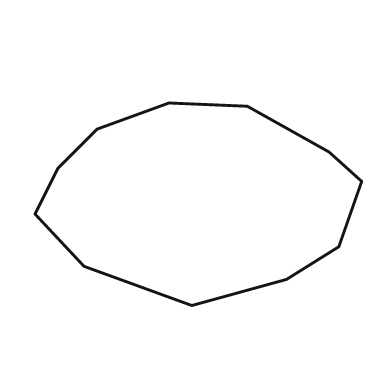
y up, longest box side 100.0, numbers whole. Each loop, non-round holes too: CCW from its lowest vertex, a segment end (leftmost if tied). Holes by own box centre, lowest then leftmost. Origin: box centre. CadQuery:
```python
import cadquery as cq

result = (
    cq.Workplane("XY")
    .moveTo(-2.0, -31.0)
    .lineTo(27.0, -23.0)
    .lineTo(43.0, -13.0)
    .lineTo(50.0, 7.0)
    .lineTo(40.0, 16.0)
    .lineTo(15.0, 30.0)
    .lineTo(-9.0, 31.0)
    .lineTo(-31.0, 23.0)
    .lineTo(-43.0, 11.0)
    .lineTo(-50.0, -3.0)
    .lineTo(-35.0, -19.0)
    .close()
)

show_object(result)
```